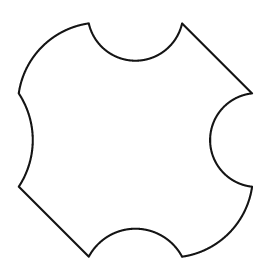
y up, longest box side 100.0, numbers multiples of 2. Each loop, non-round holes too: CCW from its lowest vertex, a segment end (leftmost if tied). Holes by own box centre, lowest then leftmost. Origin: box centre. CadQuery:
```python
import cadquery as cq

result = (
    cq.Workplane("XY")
    .moveTo(-20.0, -50.0)
    .threePointArc((0.0, -38.0), (20.0, -50.0))
    .threePointArc((40.0, -40.0), (50.0, -20.0))
    .threePointArc((32.0, 0.0), (50.0, 20.0))
    .lineTo(20.0, 50.0)
    .threePointArc((0.0, 34.0), (-20.0, 50.0))
    .threePointArc((-40.0, 40.0), (-50.0, 20.0))
    .threePointArc((-44.0, 0.0), (-50.0, -20.0))
    .close()
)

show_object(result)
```